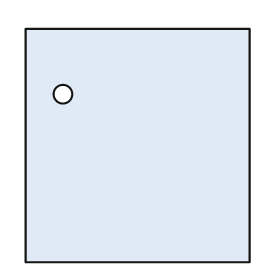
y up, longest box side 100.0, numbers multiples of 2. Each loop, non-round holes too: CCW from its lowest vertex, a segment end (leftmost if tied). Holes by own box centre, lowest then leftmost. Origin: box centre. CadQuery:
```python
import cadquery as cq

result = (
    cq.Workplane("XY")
    .moveTo(-48.0, -50.0)
    .lineTo(48.0, -50.0)
    .lineTo(48.0, 50.0)
    .lineTo(-48.0, 50.0)
    .close()
    .moveTo(-32.0, 22.0)
    .circle(4.0)
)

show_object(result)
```